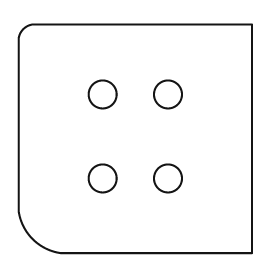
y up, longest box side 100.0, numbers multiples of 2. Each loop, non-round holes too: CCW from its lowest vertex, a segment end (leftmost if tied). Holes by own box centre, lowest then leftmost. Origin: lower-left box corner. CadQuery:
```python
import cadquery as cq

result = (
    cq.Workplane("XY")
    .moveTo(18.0, 0.0)
    .lineTo(100.0, 0.0)
    .lineTo(100.0, 98.0)
    .lineTo(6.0, 98.0)
    .threePointArc((2.0, 96.0), (0.0, 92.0))
    .lineTo(0.0, 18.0)
    .threePointArc((6.0, 6.0), (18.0, 0.0))
    .close()
    .moveTo(36.0, 32.0)
    .circle(6.0)
    .moveTo(64.0, 32.0)
    .circle(6.0)
    .moveTo(36.0, 68.0)
    .circle(6.0)
    .moveTo(64.0, 68.0)
    .circle(6.0)
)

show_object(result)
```